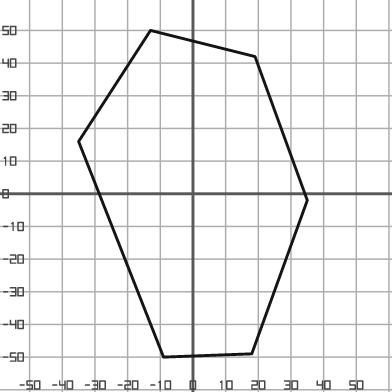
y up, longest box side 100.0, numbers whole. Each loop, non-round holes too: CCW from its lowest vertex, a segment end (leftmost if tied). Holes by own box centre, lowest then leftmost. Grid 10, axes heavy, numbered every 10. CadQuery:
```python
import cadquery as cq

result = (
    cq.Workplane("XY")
    .moveTo(-9.0, -50.0)
    .lineTo(18.0, -49.0)
    .lineTo(35.0, -2.0)
    .lineTo(19.0, 42.0)
    .lineTo(-13.0, 50.0)
    .lineTo(-35.0, 16.0)
    .close()
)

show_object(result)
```